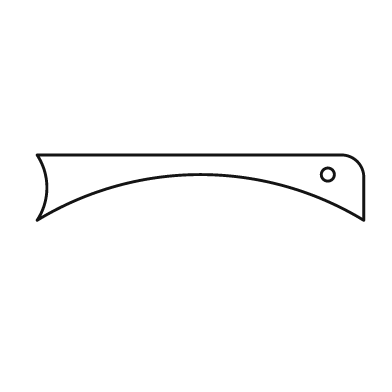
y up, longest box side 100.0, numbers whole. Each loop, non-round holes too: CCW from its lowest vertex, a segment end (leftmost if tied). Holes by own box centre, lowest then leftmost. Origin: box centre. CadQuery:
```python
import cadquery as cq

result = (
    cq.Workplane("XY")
    .moveTo(-50.0, -10.0)
    .threePointArc((0.0, 4.0), (50.0, -10.0))
    .lineTo(50.0, 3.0)
    .threePointArc((48.0, 8.0), (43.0, 10.0))
    .lineTo(-50.0, 10.0)
    .threePointArc((-47.0, 0.0), (-50.0, -10.0))
    .close()
    .moveTo(39.0, 4.0)
    .circle(2.0)
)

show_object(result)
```